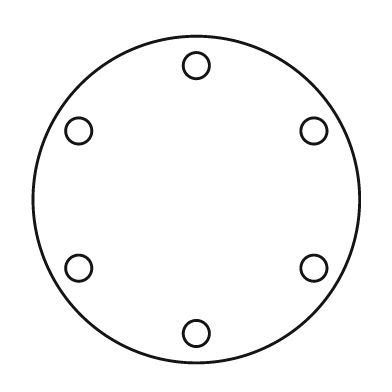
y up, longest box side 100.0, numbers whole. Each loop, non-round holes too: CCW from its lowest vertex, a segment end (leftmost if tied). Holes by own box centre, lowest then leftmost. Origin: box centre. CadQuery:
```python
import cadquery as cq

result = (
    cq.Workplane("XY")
    .moveTo(0.0, 0.0)
    .circle(50.0)
    .moveTo(0.0, -41.0)
    .circle(4.0)
    .moveTo(-36.0, -21.0)
    .circle(4.0)
    .moveTo(36.0, -21.0)
    .circle(4.0)
    .moveTo(-36.0, 21.0)
    .circle(4.0)
    .moveTo(36.0, 21.0)
    .circle(4.0)
    .moveTo(0.0, 41.0)
    .circle(4.0)
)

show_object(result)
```